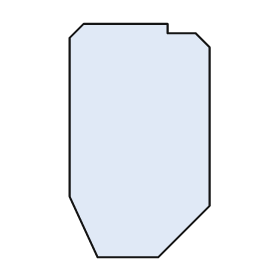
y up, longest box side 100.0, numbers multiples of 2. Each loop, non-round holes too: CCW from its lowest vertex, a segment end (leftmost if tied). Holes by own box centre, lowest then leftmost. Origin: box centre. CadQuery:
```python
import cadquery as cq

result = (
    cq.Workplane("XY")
    .moveTo(-18.0, -50.0)
    .lineTo(8.0, -50.0)
    .lineTo(30.0, -28.0)
    .lineTo(30.0, 40.0)
    .lineTo(24.0, 46.0)
    .lineTo(12.0, 46.0)
    .lineTo(12.0, 50.0)
    .lineTo(-24.0, 50.0)
    .lineTo(-30.0, 44.0)
    .lineTo(-30.0, -24.0)
    .close()
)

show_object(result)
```